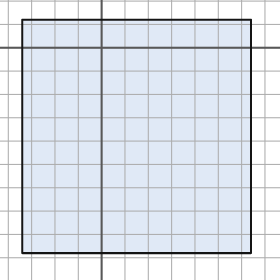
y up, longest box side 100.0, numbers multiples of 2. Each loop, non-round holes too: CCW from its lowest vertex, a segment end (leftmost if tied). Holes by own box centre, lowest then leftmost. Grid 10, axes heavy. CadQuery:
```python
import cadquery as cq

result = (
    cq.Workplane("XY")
    .moveTo(-34.0, -88.0)
    .lineTo(64.0, -88.0)
    .lineTo(64.0, 12.0)
    .lineTo(-34.0, 12.0)
    .close()
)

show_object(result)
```